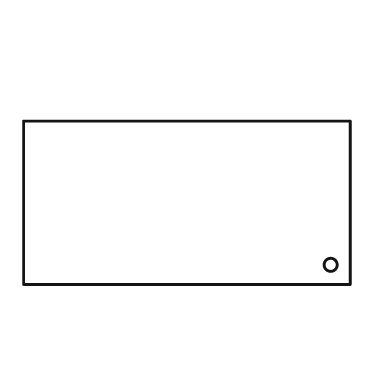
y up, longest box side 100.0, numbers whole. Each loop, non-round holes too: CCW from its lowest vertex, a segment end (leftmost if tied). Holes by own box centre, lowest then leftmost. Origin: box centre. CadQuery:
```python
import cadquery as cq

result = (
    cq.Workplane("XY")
    .moveTo(-50.0, -25.0)
    .lineTo(50.0, -25.0)
    .lineTo(50.0, 25.0)
    .lineTo(-50.0, 25.0)
    .close()
    .moveTo(44.0, -19.0)
    .circle(2.0)
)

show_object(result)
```